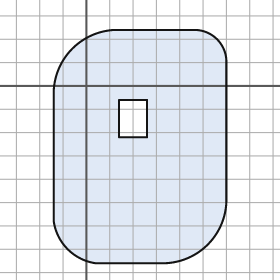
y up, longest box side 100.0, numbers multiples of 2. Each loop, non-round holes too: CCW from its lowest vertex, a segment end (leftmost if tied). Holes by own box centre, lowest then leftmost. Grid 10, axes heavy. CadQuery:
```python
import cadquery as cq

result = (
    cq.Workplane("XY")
    .moveTo(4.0, -76.0)
    .lineTo(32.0, -76.0)
    .threePointArc((52.0, -68.0), (60.0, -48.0))
    .lineTo(60.0, 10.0)
    .threePointArc((56.0, 20.0), (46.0, 24.0))
    .lineTo(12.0, 24.0)
    .threePointArc((-6.0, 16.0), (-14.0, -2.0))
    .lineTo(-14.0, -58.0)
    .threePointArc((-8.0, -70.0), (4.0, -76.0))
    .close()
    .moveTo(14.0, -22.0)
    .lineTo(26.0, -22.0)
    .lineTo(26.0, -6.0)
    .lineTo(14.0, -6.0)
    .close()
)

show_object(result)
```